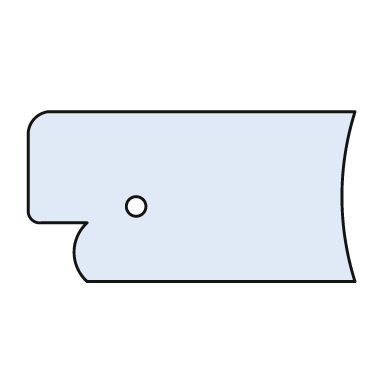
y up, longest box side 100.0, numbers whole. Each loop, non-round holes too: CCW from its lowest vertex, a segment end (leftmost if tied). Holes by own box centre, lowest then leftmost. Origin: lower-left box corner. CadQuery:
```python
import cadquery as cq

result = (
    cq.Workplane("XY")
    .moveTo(18.0, 0.0)
    .lineTo(100.0, 0.0)
    .threePointArc((96.0, 26.0), (100.0, 52.0))
    .lineTo(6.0, 52.0)
    .threePointArc((2.0, 50.0), (0.0, 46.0))
    .lineTo(0.0, 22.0)
    .threePointArc((1.0, 19.0), (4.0, 18.0))
    .lineTo(18.0, 18.0)
    .threePointArc((14.0, 9.0), (18.0, 0.0))
    .close()
    .moveTo(33.0, 23.0)
    .circle(3.0)
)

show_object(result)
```